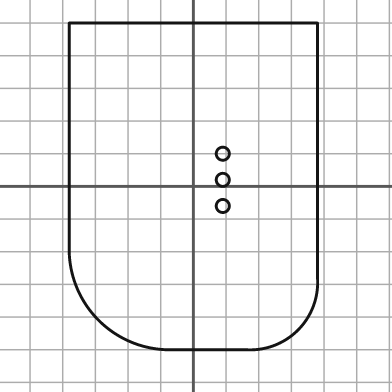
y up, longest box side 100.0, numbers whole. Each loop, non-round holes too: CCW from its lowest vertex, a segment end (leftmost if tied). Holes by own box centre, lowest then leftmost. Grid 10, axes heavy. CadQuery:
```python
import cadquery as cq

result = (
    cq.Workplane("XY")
    .moveTo(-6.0, -50.0)
    .lineTo(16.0, -50.0)
    .threePointArc((32.0, -44.0), (38.0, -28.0))
    .lineTo(38.0, 50.0)
    .lineTo(-38.0, 50.0)
    .lineTo(-38.0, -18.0)
    .threePointArc((-29.0, -41.0), (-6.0, -50.0))
    .close()
    .moveTo(9.0, -6.0)
    .circle(2.0)
    .moveTo(9.0, 2.0)
    .circle(2.0)
    .moveTo(9.0, 10.0)
    .circle(2.0)
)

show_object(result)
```